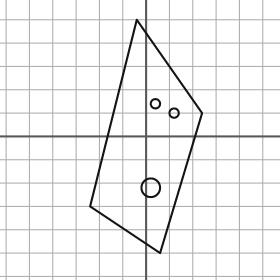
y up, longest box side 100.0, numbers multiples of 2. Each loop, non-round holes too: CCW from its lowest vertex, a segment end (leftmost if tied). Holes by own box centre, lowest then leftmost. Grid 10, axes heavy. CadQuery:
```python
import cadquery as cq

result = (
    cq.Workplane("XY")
    .moveTo(6.0, -50.0)
    .lineTo(24.0, 10.0)
    .lineTo(-4.0, 50.0)
    .lineTo(-24.0, -30.0)
    .close()
    .moveTo(2.0, -22.0)
    .circle(4.0)
    .moveTo(12.0, 10.0)
    .circle(2.0)
    .moveTo(4.0, 14.0)
    .circle(2.0)
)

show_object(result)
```